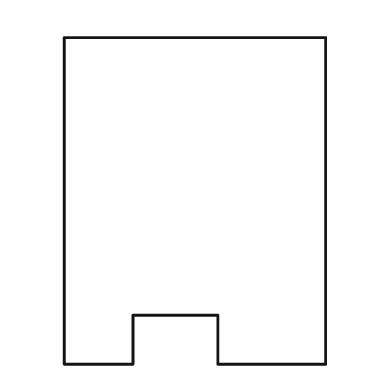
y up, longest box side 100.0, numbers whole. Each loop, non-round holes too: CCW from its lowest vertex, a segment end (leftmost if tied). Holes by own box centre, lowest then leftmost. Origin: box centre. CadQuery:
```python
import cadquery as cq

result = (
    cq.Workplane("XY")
    .moveTo(-40.0, -50.0)
    .lineTo(-19.0, -50.0)
    .lineTo(-19.0, -35.0)
    .lineTo(7.0, -35.0)
    .lineTo(7.0, -50.0)
    .lineTo(40.0, -50.0)
    .lineTo(40.0, 50.0)
    .lineTo(-40.0, 50.0)
    .close()
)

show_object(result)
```